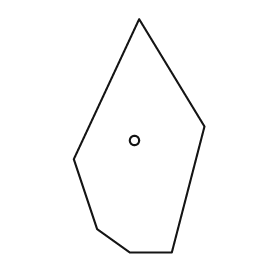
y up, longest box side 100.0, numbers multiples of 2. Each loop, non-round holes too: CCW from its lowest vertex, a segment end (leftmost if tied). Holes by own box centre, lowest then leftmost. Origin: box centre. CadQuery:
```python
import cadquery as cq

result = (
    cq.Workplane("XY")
    .moveTo(-4.0, -50.0)
    .lineTo(14.0, -50.0)
    .lineTo(28.0, 4.0)
    .lineTo(0.0, 50.0)
    .lineTo(-28.0, -10.0)
    .lineTo(-18.0, -40.0)
    .close()
    .moveTo(-2.0, -2.0)
    .circle(2.0)
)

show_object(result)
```